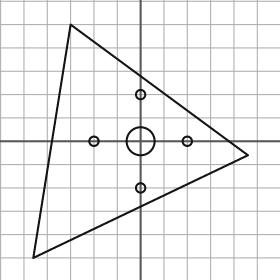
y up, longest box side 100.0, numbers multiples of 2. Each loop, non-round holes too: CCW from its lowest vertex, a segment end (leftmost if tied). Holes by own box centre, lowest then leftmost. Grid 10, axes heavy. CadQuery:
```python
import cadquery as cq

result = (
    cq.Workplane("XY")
    .moveTo(-46.0, -50.0)
    .lineTo(46.0, -6.0)
    .lineTo(-30.0, 50.0)
    .close()
    .moveTo(0.0, -20.0)
    .circle(2.0)
    .moveTo(-20.0, 0.0)
    .circle(2.0)
    .moveTo(0.0, 0.0)
    .circle(6.0)
    .moveTo(20.0, 0.0)
    .circle(2.0)
    .moveTo(0.0, 20.0)
    .circle(2.0)
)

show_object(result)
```